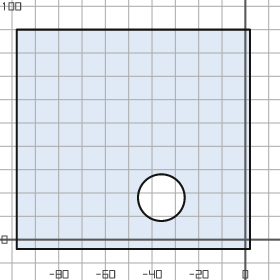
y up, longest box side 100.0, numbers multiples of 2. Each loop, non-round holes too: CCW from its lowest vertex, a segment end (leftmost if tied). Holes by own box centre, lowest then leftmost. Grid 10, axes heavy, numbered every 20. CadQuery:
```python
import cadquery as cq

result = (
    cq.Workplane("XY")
    .moveTo(-98.0, -4.0)
    .lineTo(2.0, -4.0)
    .lineTo(2.0, 90.0)
    .lineTo(-98.0, 90.0)
    .close()
    .moveTo(-36.0, 18.0)
    .circle(10.0)
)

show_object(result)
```